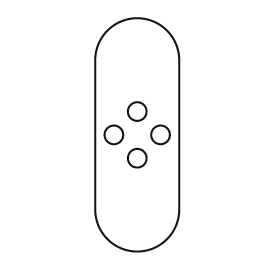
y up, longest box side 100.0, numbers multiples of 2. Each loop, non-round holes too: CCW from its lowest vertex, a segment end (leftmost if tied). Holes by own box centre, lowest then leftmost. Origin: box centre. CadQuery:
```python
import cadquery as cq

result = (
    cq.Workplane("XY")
    .moveTo(-18.0, -32.0)
    .threePointArc((0.0, -50.0), (18.0, -32.0))
    .lineTo(18.0, 32.0)
    .threePointArc((0.0, 50.0), (-18.0, 32.0))
    .close()
    .moveTo(0.0, -10.0)
    .circle(4.0)
    .moveTo(-10.0, 0.0)
    .circle(4.0)
    .moveTo(10.0, 0.0)
    .circle(4.0)
    .moveTo(0.0, 10.0)
    .circle(4.0)
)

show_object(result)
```